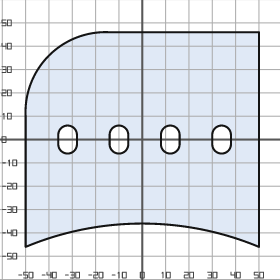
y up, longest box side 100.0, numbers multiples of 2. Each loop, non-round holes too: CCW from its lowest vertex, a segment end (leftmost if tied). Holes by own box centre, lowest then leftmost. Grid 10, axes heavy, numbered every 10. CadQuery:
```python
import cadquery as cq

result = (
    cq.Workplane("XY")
    .moveTo(-50.0, -46.0)
    .threePointArc((0.0, -36.0), (50.0, -46.0))
    .lineTo(50.0, 46.0)
    .lineTo(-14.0, 46.0)
    .threePointArc((-40.0, 36.0), (-50.0, 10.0))
    .close()
    .moveTo(-36.0, -2.0)
    .threePointArc((-32.0, -6.0), (-28.0, -2.0))
    .lineTo(-28.0, 2.0)
    .threePointArc((-32.0, 6.0), (-36.0, 2.0))
    .close()
    .moveTo(-14.0, -2.0)
    .threePointArc((-10.0, -6.0), (-6.0, -2.0))
    .lineTo(-6.0, 2.0)
    .threePointArc((-10.0, 6.0), (-14.0, 2.0))
    .close()
    .moveTo(8.0, -2.0)
    .threePointArc((12.0, -6.0), (16.0, -2.0))
    .lineTo(16.0, 2.0)
    .threePointArc((12.0, 6.0), (8.0, 2.0))
    .close()
    .moveTo(30.0, -2.0)
    .threePointArc((34.0, -6.0), (38.0, -2.0))
    .lineTo(38.0, 2.0)
    .threePointArc((34.0, 6.0), (30.0, 2.0))
    .close()
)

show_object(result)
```